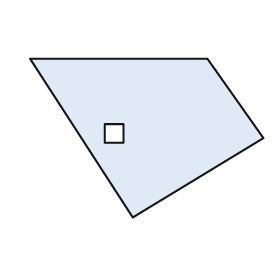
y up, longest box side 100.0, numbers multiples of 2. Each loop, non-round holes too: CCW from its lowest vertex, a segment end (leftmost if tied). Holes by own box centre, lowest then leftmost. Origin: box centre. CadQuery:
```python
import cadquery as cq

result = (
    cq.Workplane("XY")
    .moveTo(-6.0, -34.0)
    .lineTo(50.0, 0.0)
    .lineTo(26.0, 34.0)
    .lineTo(-50.0, 34.0)
    .close()
    .moveTo(-18.0, -2.0)
    .lineTo(-10.0, -2.0)
    .lineTo(-10.0, 6.0)
    .lineTo(-18.0, 6.0)
    .close()
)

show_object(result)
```